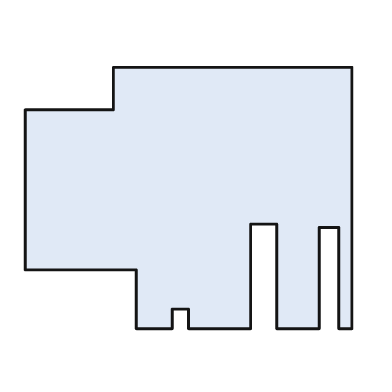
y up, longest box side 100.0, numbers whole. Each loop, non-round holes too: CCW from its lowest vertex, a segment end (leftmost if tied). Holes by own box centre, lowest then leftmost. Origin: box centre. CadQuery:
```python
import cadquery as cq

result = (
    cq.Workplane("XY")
    .moveTo(-16.0, -40.0)
    .lineTo(-5.0, -40.0)
    .lineTo(-5.0, -34.0)
    .lineTo(0.0, -34.0)
    .lineTo(0.0, -40.0)
    .lineTo(19.0, -40.0)
    .lineTo(19.0, -8.0)
    .lineTo(27.0, -8.0)
    .lineTo(27.0, -40.0)
    .lineTo(40.0, -40.0)
    .lineTo(40.0, -9.0)
    .lineTo(46.0, -9.0)
    .lineTo(46.0, -40.0)
    .lineTo(50.0, -40.0)
    .lineTo(50.0, 40.0)
    .lineTo(-23.0, 40.0)
    .lineTo(-23.0, 27.0)
    .lineTo(-50.0, 27.0)
    .lineTo(-50.0, -22.0)
    .lineTo(-16.0, -22.0)
    .close()
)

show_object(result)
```